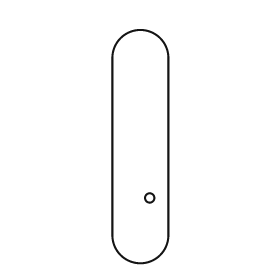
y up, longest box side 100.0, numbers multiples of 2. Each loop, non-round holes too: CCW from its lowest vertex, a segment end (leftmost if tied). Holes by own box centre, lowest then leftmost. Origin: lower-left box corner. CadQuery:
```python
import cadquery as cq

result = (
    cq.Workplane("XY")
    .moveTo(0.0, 12.0)
    .threePointArc((12.0, 0.0), (24.0, 12.0))
    .lineTo(24.0, 88.0)
    .threePointArc((12.0, 100.0), (0.0, 88.0))
    .close()
    .moveTo(16.0, 28.0)
    .circle(2.0)
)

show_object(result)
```